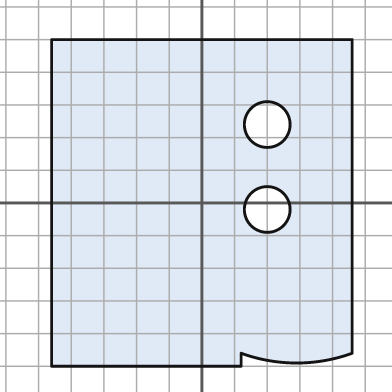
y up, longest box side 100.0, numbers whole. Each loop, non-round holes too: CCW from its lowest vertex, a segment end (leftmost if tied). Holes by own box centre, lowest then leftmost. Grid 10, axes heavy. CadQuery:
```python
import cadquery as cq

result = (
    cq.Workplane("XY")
    .moveTo(-46.0, -50.0)
    .lineTo(12.0, -50.0)
    .lineTo(12.0, -46.0)
    .threePointArc((29.0, -49.0), (46.0, -46.0))
    .lineTo(46.0, 50.0)
    .lineTo(-46.0, 50.0)
    .close()
    .moveTo(20.0, -2.0)
    .circle(7.0)
    .moveTo(20.0, 24.0)
    .circle(7.0)
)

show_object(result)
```